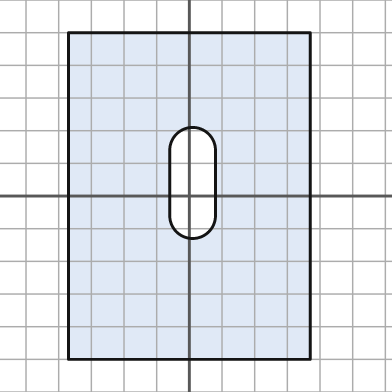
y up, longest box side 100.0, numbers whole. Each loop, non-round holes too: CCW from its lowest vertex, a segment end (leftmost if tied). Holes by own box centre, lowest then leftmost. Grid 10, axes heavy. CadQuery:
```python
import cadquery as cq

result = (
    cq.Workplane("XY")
    .moveTo(-37.0, -50.0)
    .lineTo(37.0, -50.0)
    .lineTo(37.0, 50.0)
    .lineTo(-37.0, 50.0)
    .close()
    .moveTo(-6.0, -6.0)
    .threePointArc((1.0, -13.0), (8.0, -6.0))
    .lineTo(8.0, 14.0)
    .threePointArc((1.0, 21.0), (-6.0, 14.0))
    .close()
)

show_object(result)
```